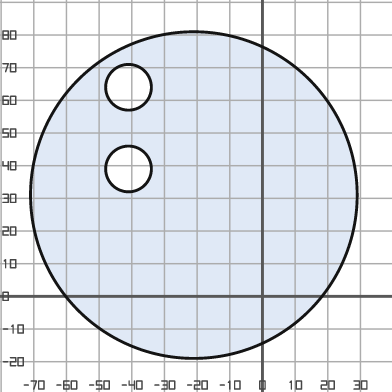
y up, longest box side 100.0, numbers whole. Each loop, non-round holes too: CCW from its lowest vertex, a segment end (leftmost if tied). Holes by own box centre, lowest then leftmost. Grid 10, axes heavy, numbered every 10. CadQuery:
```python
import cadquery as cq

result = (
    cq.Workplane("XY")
    .moveTo(-21.0, 31.0)
    .circle(50.0)
    .moveTo(-41.0, 39.0)
    .circle(7.0)
    .moveTo(-41.0, 64.0)
    .circle(7.0)
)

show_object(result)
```